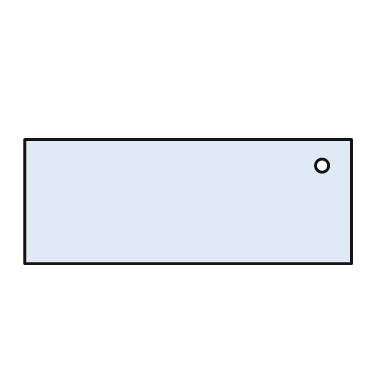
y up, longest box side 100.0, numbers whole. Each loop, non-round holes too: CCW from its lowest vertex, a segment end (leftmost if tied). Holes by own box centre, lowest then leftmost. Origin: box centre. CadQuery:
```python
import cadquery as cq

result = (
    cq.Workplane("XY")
    .moveTo(-50.0, -19.0)
    .lineTo(50.0, -19.0)
    .lineTo(50.0, 19.0)
    .lineTo(-50.0, 19.0)
    .close()
    .moveTo(41.0, 11.0)
    .circle(2.0)
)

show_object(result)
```